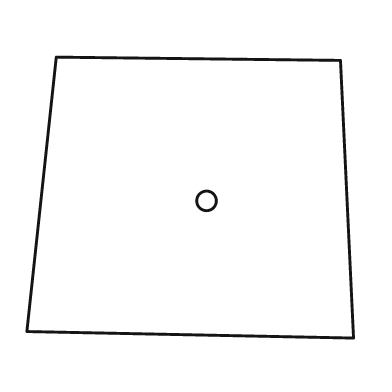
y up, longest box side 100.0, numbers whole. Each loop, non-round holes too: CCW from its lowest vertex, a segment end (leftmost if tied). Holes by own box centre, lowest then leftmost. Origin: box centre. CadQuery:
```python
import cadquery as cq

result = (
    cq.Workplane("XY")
    .moveTo(50.0, -43.0)
    .lineTo(46.0, 42.0)
    .lineTo(-41.0, 43.0)
    .lineTo(-50.0, -41.0)
    .close()
    .moveTo(5.0, -1.0)
    .circle(3.0)
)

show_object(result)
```